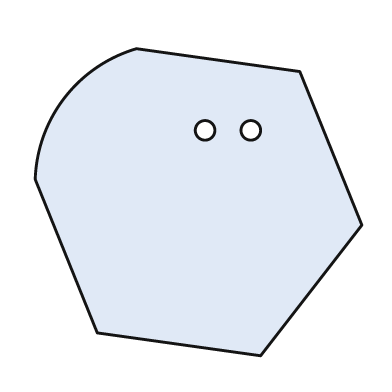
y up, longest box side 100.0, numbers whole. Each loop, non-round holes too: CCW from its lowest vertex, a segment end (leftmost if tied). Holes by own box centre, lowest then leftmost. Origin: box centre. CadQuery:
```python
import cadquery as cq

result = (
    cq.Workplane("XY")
    .moveTo(19.0, -47.0)
    .lineTo(50.0, -7.0)
    .lineTo(31.0, 40.0)
    .lineTo(-19.0, 47.0)
    .threePointArc((-41.0, 32.0), (-50.0, 7.0))
    .lineTo(-31.0, -40.0)
    .close()
    .moveTo(2.0, 22.0)
    .circle(3.0)
    .moveTo(16.0, 22.0)
    .circle(3.0)
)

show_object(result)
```